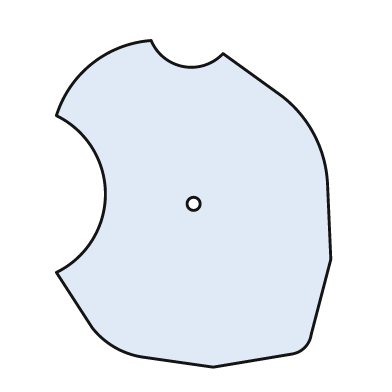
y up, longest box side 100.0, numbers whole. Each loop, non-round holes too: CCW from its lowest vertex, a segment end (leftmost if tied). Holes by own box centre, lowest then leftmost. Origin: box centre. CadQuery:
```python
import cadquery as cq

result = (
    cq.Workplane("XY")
    .moveTo(6.0, -50.0)
    .lineTo(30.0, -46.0)
    .threePointArc((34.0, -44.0), (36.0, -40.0))
    .lineTo(42.0, -17.0)
    .lineTo(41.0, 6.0)
    .threePointArc((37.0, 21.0), (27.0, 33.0))
    .lineTo(9.0, 46.0)
    .threePointArc((-3.0, 42.0), (-13.0, 50.0))
    .threePointArc((-31.0, 43.0), (-42.0, 27.0))
    .threePointArc((-27.0, 3.0), (-42.0, -21.0))
    .lineTo(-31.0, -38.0)
    .threePointArc((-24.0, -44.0), (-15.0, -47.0))
    .close()
    .moveTo(0.0, 0.0)
    .circle(2.0)
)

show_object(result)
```